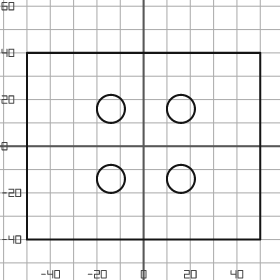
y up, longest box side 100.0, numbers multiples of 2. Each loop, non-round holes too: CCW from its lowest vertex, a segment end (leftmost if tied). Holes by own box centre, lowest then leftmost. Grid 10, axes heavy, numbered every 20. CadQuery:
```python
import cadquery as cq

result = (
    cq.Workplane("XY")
    .moveTo(-50.0, -40.0)
    .lineTo(50.0, -40.0)
    .lineTo(50.0, 40.0)
    .lineTo(-50.0, 40.0)
    .close()
    .moveTo(-14.0, -14.0)
    .circle(6.0)
    .moveTo(16.0, -14.0)
    .circle(6.0)
    .moveTo(-14.0, 16.0)
    .circle(6.0)
    .moveTo(16.0, 16.0)
    .circle(6.0)
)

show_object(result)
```